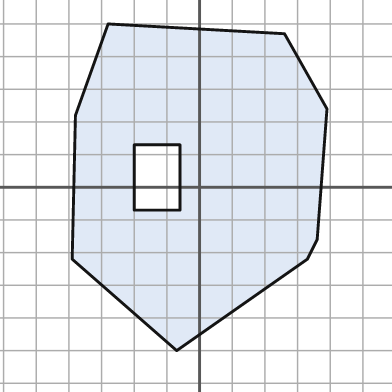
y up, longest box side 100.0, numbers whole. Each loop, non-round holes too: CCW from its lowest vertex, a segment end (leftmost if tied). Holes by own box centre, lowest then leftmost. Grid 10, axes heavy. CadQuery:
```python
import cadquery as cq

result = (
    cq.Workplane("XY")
    .moveTo(-7.0, -50.0)
    .lineTo(33.0, -22.0)
    .lineTo(36.0, -16.0)
    .lineTo(39.0, 24.0)
    .lineTo(26.0, 47.0)
    .lineTo(-28.0, 50.0)
    .lineTo(-38.0, 22.0)
    .lineTo(-39.0, -22.0)
    .close()
    .moveTo(-20.0, -7.0)
    .lineTo(-6.0, -7.0)
    .lineTo(-6.0, 13.0)
    .lineTo(-20.0, 13.0)
    .close()
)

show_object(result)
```